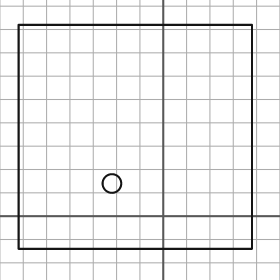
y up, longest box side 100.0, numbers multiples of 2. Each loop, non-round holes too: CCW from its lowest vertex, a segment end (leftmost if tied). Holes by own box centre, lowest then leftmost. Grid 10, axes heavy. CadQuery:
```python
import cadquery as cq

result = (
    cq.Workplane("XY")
    .moveTo(-62.0, -14.0)
    .lineTo(38.0, -14.0)
    .lineTo(38.0, 82.0)
    .lineTo(-62.0, 82.0)
    .close()
    .moveTo(-22.0, 14.0)
    .circle(4.0)
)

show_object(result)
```